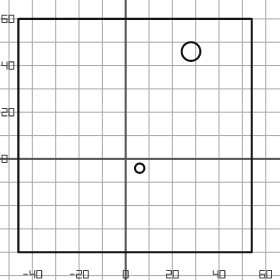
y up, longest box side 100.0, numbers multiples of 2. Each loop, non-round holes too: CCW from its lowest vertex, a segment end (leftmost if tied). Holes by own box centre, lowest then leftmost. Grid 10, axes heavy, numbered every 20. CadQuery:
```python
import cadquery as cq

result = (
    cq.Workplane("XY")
    .moveTo(-46.0, -40.0)
    .lineTo(54.0, -40.0)
    .lineTo(54.0, 60.0)
    .lineTo(-46.0, 60.0)
    .close()
    .moveTo(6.0, -4.0)
    .circle(2.0)
    .moveTo(28.0, 46.0)
    .circle(4.0)
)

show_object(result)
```